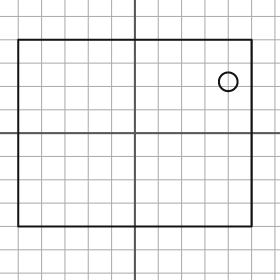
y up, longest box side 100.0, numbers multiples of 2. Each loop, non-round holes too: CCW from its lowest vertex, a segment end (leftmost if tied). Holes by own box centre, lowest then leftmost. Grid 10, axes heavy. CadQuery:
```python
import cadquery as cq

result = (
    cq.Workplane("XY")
    .moveTo(-50.0, -40.0)
    .lineTo(50.0, -40.0)
    .lineTo(50.0, 40.0)
    .lineTo(-50.0, 40.0)
    .close()
    .moveTo(40.0, 22.0)
    .circle(4.0)
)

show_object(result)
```